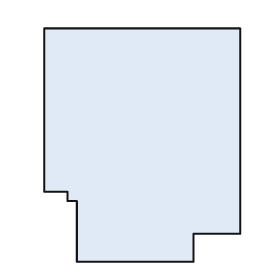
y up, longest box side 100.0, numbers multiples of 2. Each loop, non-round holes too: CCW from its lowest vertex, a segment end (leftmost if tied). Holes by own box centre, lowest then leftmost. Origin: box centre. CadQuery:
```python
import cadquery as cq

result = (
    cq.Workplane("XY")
    .moveTo(-28.0, -50.0)
    .lineTo(22.0, -50.0)
    .lineTo(22.0, -38.0)
    .lineTo(42.0, -38.0)
    .lineTo(42.0, 50.0)
    .lineTo(-42.0, 50.0)
    .lineTo(-42.0, -20.0)
    .lineTo(-32.0, -20.0)
    .lineTo(-32.0, -24.0)
    .lineTo(-28.0, -24.0)
    .close()
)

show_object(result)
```